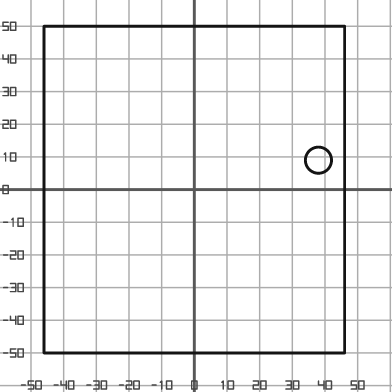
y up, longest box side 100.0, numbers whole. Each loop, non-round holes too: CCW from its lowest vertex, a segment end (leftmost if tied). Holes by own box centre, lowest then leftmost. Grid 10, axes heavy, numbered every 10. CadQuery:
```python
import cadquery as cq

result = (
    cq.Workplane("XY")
    .moveTo(-46.0, -50.0)
    .lineTo(46.0, -50.0)
    .lineTo(46.0, 50.0)
    .lineTo(-46.0, 50.0)
    .close()
    .moveTo(38.0, 9.0)
    .circle(4.0)
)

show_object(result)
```